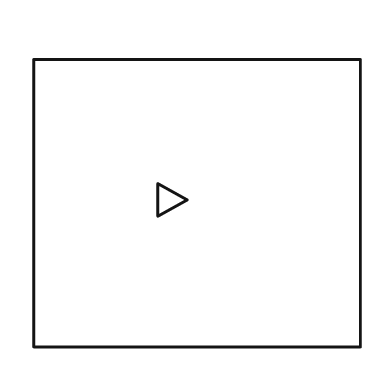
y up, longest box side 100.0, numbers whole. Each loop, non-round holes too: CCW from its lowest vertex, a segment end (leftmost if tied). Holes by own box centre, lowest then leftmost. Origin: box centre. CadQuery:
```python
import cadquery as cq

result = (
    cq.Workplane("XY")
    .moveTo(-50.0, -44.0)
    .lineTo(50.0, -44.0)
    .lineTo(50.0, 44.0)
    .lineTo(-50.0, 44.0)
    .close()
    .moveTo(-12.0, -4.0)
    .lineTo(-3.0, 1.0)
    .lineTo(-12.0, 6.0)
    .close()
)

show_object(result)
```